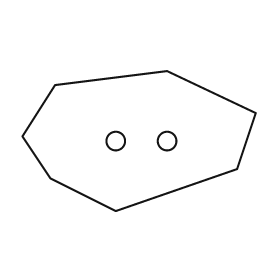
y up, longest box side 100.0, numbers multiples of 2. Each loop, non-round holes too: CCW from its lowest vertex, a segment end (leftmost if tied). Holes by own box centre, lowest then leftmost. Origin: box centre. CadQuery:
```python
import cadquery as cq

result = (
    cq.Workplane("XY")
    .moveTo(-10.0, -30.0)
    .lineTo(42.0, -12.0)
    .lineTo(50.0, 12.0)
    .lineTo(12.0, 30.0)
    .lineTo(-36.0, 24.0)
    .lineTo(-50.0, 2.0)
    .lineTo(-38.0, -16.0)
    .close()
    .moveTo(-10.0, 0.0)
    .circle(4.0)
    .moveTo(12.0, 0.0)
    .circle(4.0)
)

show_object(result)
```